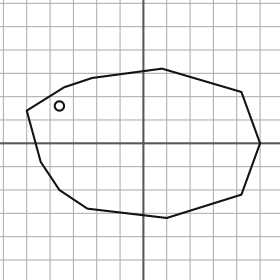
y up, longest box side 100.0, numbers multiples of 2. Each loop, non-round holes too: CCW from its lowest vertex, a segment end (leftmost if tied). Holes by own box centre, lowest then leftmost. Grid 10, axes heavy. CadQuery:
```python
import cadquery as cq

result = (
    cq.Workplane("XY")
    .moveTo(10.0, -32.0)
    .lineTo(42.0, -22.0)
    .lineTo(50.0, 0.0)
    .lineTo(42.0, 22.0)
    .lineTo(8.0, 32.0)
    .lineTo(-22.0, 28.0)
    .lineTo(-34.0, 24.0)
    .lineTo(-50.0, 14.0)
    .lineTo(-44.0, -8.0)
    .lineTo(-36.0, -20.0)
    .lineTo(-24.0, -28.0)
    .close()
    .moveTo(-36.0, 16.0)
    .circle(2.0)
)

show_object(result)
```